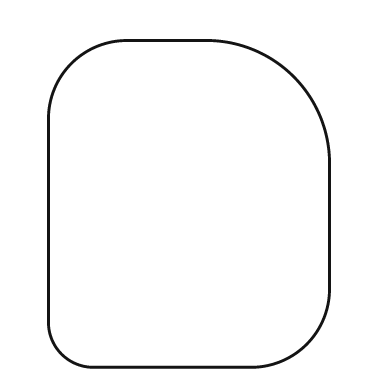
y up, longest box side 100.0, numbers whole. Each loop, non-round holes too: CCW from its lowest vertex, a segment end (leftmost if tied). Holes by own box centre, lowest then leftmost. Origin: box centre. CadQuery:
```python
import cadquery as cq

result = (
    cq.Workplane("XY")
    .moveTo(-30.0, -50.0)
    .lineTo(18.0, -50.0)
    .threePointArc((36.0, -43.0), (43.0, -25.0))
    .lineTo(43.0, 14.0)
    .threePointArc((32.0, 39.0), (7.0, 50.0))
    .lineTo(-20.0, 50.0)
    .threePointArc((-36.0, 43.0), (-43.0, 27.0))
    .lineTo(-43.0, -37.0)
    .threePointArc((-39.0, -46.0), (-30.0, -50.0))
    .close()
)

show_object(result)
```